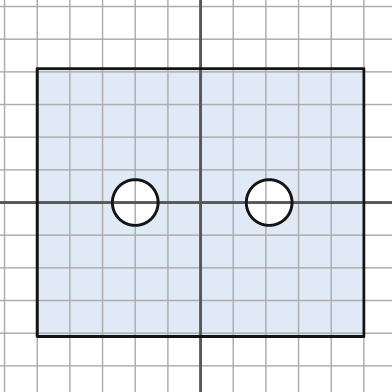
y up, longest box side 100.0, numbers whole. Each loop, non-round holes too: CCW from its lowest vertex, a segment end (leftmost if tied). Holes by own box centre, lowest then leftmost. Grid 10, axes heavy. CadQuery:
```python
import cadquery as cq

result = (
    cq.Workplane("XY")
    .moveTo(-50.0, -41.0)
    .lineTo(50.0, -41.0)
    .lineTo(50.0, 41.0)
    .lineTo(-50.0, 41.0)
    .close()
    .moveTo(-20.0, 0.0)
    .circle(7.0)
    .moveTo(21.0, 0.0)
    .circle(7.0)
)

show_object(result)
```